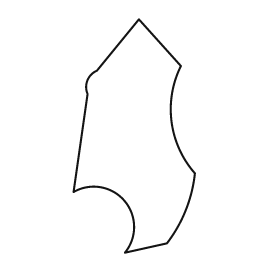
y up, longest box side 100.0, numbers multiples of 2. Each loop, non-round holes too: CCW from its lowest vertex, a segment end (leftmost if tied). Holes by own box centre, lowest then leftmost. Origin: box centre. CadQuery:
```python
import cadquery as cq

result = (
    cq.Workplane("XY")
    .moveTo(-4.0, -50.0)
    .lineTo(14.0, -46.0)
    .threePointArc((22.0, -32.0), (26.0, -16.0))
    .threePointArc((16.0, 6.0), (20.0, 30.0))
    .lineTo(2.0, 50.0)
    .lineTo(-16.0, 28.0)
    .threePointArc((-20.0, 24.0), (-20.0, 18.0))
    .lineTo(-26.0, -24.0)
    .threePointArc((-4.0, -28.0), (-4.0, -50.0))
    .close()
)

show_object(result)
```